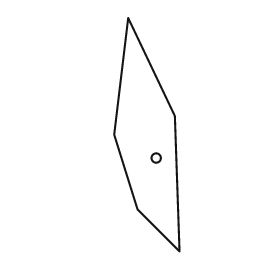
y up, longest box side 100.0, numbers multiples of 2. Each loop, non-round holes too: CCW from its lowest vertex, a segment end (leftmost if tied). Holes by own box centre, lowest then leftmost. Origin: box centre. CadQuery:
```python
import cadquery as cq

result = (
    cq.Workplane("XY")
    .moveTo(14.0, -50.0)
    .lineTo(12.0, 8.0)
    .lineTo(-8.0, 50.0)
    .lineTo(-14.0, 0.0)
    .lineTo(-4.0, -32.0)
    .close()
    .moveTo(4.0, -10.0)
    .circle(2.0)
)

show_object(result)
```